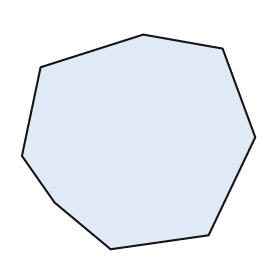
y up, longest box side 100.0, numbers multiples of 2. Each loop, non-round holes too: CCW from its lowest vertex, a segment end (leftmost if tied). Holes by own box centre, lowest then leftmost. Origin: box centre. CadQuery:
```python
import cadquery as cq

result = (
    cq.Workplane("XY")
    .moveTo(-12.0, -46.0)
    .lineTo(30.0, -40.0)
    .lineTo(50.0, 2.0)
    .lineTo(36.0, 40.0)
    .lineTo(2.0, 46.0)
    .lineTo(-42.0, 32.0)
    .lineTo(-50.0, -6.0)
    .lineTo(-36.0, -26.0)
    .close()
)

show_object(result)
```